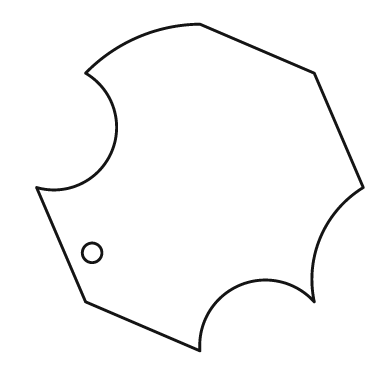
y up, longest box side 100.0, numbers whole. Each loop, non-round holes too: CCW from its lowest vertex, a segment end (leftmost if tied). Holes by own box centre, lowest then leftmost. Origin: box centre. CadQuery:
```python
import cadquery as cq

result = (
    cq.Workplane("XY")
    .moveTo(0.0, -50.0)
    .threePointArc((12.0, -30.0), (35.0, -35.0))
    .threePointArc((37.0, -15.0), (50.0, 0.0))
    .lineTo(35.0, 35.0)
    .lineTo(0.0, 50.0)
    .threePointArc((-19.0, 46.0), (-35.0, 35.0))
    .threePointArc((-27.0, 11.0), (-50.0, 0.0))
    .lineTo(-35.0, -35.0)
    .close()
    .moveTo(-33.0, -20.0)
    .circle(3.0)
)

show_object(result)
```